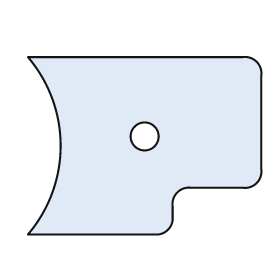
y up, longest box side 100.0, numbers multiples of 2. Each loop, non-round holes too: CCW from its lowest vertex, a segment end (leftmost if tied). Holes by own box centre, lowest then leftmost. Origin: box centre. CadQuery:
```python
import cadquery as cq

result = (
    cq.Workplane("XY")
    .moveTo(-50.0, -38.0)
    .lineTo(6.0, -38.0)
    .threePointArc((10.0, -36.0), (12.0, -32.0))
    .lineTo(12.0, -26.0)
    .threePointArc((14.0, -20.0), (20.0, -18.0))
    .lineTo(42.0, -18.0)
    .threePointArc((48.0, -16.0), (50.0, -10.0))
    .lineTo(50.0, 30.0)
    .threePointArc((48.0, 36.0), (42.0, 38.0))
    .lineTo(-50.0, 38.0)
    .threePointArc((-36.0, 0.0), (-50.0, -38.0))
    .close()
    .moveTo(0.0, 4.0)
    .circle(6.0)
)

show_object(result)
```